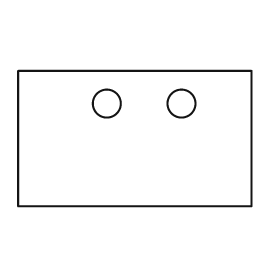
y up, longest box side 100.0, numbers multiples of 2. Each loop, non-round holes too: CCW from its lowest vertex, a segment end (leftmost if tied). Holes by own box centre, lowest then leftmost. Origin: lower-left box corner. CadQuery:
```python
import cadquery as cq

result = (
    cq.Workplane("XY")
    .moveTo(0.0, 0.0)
    .lineTo(100.0, 0.0)
    .lineTo(100.0, 58.0)
    .lineTo(0.0, 58.0)
    .close()
    .moveTo(38.0, 44.0)
    .circle(6.0)
    .moveTo(70.0, 44.0)
    .circle(6.0)
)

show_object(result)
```